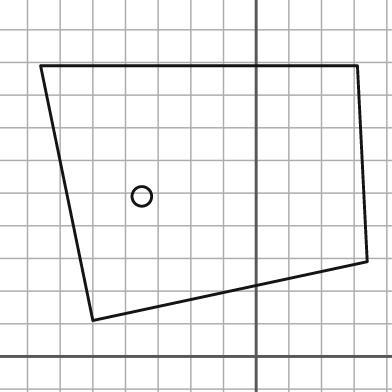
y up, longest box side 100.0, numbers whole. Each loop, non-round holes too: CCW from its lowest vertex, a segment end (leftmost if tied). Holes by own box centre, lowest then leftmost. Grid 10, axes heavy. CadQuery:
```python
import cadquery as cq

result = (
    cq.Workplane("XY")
    .moveTo(-50.0, 11.0)
    .lineTo(34.0, 29.0)
    .lineTo(31.0, 89.0)
    .lineTo(-66.0, 89.0)
    .close()
    .moveTo(-35.0, 49.0)
    .circle(3.0)
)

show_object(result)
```